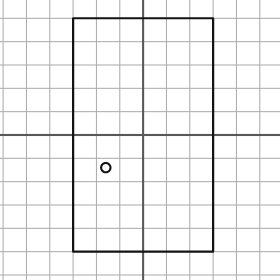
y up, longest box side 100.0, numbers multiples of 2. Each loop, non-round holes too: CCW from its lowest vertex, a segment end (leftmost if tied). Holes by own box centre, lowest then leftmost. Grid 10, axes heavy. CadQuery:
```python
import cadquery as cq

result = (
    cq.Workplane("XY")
    .moveTo(-30.0, -50.0)
    .lineTo(30.0, -50.0)
    .lineTo(30.0, 50.0)
    .lineTo(-30.0, 50.0)
    .close()
    .moveTo(-16.0, -14.0)
    .circle(2.0)
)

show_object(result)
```